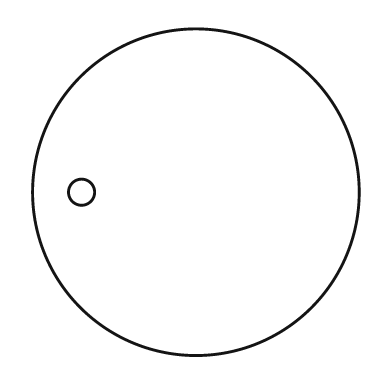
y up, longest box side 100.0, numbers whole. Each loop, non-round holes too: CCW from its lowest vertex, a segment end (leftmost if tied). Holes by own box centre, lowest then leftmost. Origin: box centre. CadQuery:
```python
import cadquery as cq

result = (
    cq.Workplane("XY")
    .moveTo(0.0, 0.0)
    .circle(50.0)
    .moveTo(-35.0, 0.0)
    .circle(4.0)
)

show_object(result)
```